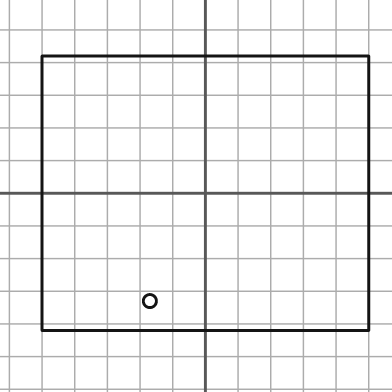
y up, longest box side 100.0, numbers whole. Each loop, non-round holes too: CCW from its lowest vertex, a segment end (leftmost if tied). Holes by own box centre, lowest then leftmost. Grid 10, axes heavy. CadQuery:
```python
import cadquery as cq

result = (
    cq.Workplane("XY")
    .moveTo(-50.0, -42.0)
    .lineTo(50.0, -42.0)
    .lineTo(50.0, 42.0)
    .lineTo(-50.0, 42.0)
    .close()
    .moveTo(-17.0, -33.0)
    .circle(2.0)
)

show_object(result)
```